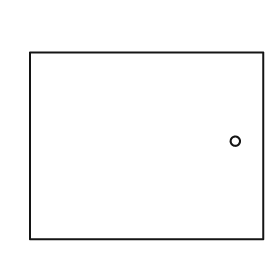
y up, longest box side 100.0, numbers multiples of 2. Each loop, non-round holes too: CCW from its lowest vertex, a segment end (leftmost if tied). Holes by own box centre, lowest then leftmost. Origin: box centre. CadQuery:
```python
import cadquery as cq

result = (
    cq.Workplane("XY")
    .moveTo(-50.0, -40.0)
    .lineTo(50.0, -40.0)
    .lineTo(50.0, 40.0)
    .lineTo(-50.0, 40.0)
    .close()
    .moveTo(38.0, 2.0)
    .circle(2.0)
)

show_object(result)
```